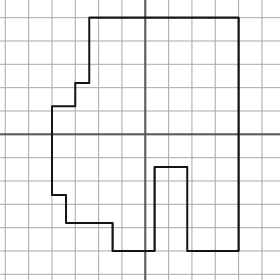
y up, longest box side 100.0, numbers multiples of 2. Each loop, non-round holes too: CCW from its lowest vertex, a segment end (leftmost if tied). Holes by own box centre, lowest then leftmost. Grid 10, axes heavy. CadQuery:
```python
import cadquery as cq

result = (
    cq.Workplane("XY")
    .moveTo(-14.0, -50.0)
    .lineTo(4.0, -50.0)
    .lineTo(4.0, -14.0)
    .lineTo(18.0, -14.0)
    .lineTo(18.0, -50.0)
    .lineTo(40.0, -50.0)
    .lineTo(40.0, 50.0)
    .lineTo(-24.0, 50.0)
    .lineTo(-24.0, 22.0)
    .lineTo(-30.0, 22.0)
    .lineTo(-30.0, 12.0)
    .lineTo(-40.0, 12.0)
    .lineTo(-40.0, -26.0)
    .lineTo(-34.0, -26.0)
    .lineTo(-34.0, -38.0)
    .lineTo(-14.0, -38.0)
    .close()
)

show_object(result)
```